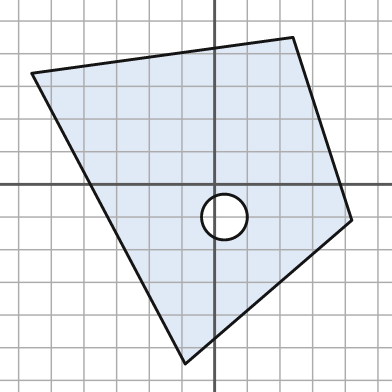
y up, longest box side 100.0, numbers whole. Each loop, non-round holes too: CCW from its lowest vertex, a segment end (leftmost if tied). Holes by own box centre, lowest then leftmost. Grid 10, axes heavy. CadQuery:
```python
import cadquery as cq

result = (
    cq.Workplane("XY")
    .moveTo(-9.0, -55.0)
    .lineTo(42.0, -11.0)
    .lineTo(24.0, 45.0)
    .lineTo(-56.0, 34.0)
    .close()
    .moveTo(3.0, -10.0)
    .circle(7.0)
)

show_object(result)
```